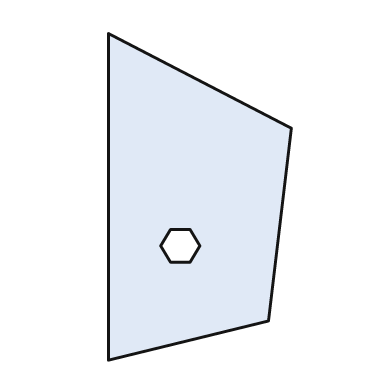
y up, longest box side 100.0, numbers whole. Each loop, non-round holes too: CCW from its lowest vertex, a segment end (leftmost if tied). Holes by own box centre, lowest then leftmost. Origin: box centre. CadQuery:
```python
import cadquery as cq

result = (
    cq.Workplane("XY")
    .moveTo(-28.0, -50.0)
    .lineTo(21.0, -38.0)
    .lineTo(28.0, 21.0)
    .lineTo(-28.0, 50.0)
    .close()
    .moveTo(-9.0, -20.0)
    .lineTo(-3.0, -20.0)
    .lineTo(0.0, -15.0)
    .lineTo(-3.0, -10.0)
    .lineTo(-9.0, -10.0)
    .lineTo(-12.0, -15.0)
    .close()
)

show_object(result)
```